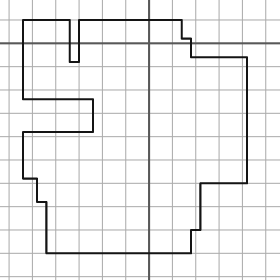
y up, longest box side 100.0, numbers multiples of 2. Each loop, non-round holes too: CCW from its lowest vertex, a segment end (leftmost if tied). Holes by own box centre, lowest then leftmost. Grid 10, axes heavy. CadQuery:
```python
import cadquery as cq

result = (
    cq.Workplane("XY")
    .moveTo(-44.0, -90.0)
    .lineTo(18.0, -90.0)
    .lineTo(18.0, -80.0)
    .lineTo(22.0, -80.0)
    .lineTo(22.0, -60.0)
    .lineTo(42.0, -60.0)
    .lineTo(42.0, -6.0)
    .lineTo(18.0, -6.0)
    .lineTo(18.0, 2.0)
    .lineTo(14.0, 2.0)
    .lineTo(14.0, 10.0)
    .lineTo(-30.0, 10.0)
    .lineTo(-30.0, -8.0)
    .lineTo(-34.0, -8.0)
    .lineTo(-34.0, 10.0)
    .lineTo(-54.0, 10.0)
    .lineTo(-54.0, -24.0)
    .lineTo(-24.0, -24.0)
    .lineTo(-24.0, -38.0)
    .lineTo(-54.0, -38.0)
    .lineTo(-54.0, -58.0)
    .lineTo(-48.0, -58.0)
    .lineTo(-48.0, -68.0)
    .lineTo(-44.0, -68.0)
    .close()
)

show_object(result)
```